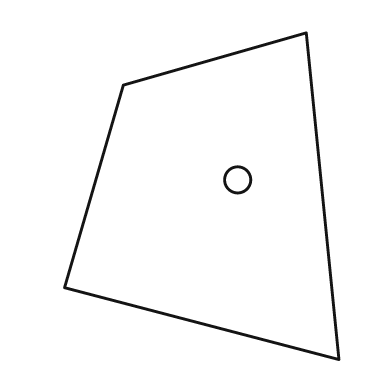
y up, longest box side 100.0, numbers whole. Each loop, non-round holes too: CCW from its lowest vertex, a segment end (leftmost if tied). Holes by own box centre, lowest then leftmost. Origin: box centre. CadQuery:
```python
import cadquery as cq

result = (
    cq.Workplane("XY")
    .moveTo(42.0, -50.0)
    .lineTo(32.0, 50.0)
    .lineTo(-24.0, 34.0)
    .lineTo(-42.0, -28.0)
    .close()
    .moveTo(11.0, 5.0)
    .circle(4.0)
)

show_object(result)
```